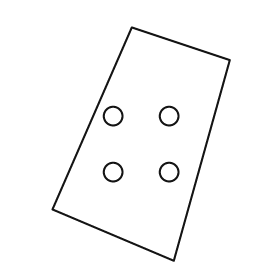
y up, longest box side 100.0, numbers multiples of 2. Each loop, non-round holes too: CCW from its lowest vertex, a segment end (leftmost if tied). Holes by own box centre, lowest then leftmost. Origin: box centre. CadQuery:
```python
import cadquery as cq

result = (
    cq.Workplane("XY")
    .moveTo(14.0, -50.0)
    .lineTo(38.0, 36.0)
    .lineTo(-4.0, 50.0)
    .lineTo(-38.0, -28.0)
    .close()
    .moveTo(-12.0, -12.0)
    .circle(4.0)
    .moveTo(12.0, -12.0)
    .circle(4.0)
    .moveTo(-12.0, 12.0)
    .circle(4.0)
    .moveTo(12.0, 12.0)
    .circle(4.0)
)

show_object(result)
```